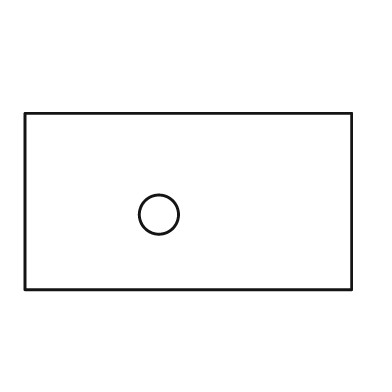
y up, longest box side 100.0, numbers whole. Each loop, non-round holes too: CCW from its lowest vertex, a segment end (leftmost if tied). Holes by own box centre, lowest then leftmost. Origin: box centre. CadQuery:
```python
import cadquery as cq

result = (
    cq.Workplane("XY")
    .moveTo(-50.0, -27.0)
    .lineTo(50.0, -27.0)
    .lineTo(50.0, 27.0)
    .lineTo(-50.0, 27.0)
    .close()
    .moveTo(-9.0, -4.0)
    .circle(6.0)
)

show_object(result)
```